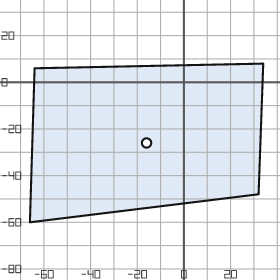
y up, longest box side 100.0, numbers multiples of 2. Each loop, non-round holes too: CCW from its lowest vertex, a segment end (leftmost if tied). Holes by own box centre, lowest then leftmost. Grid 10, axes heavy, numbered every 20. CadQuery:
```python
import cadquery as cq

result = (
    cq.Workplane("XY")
    .moveTo(-66.0, -60.0)
    .lineTo(32.0, -48.0)
    .lineTo(34.0, 8.0)
    .lineTo(-64.0, 6.0)
    .close()
    .moveTo(-16.0, -26.0)
    .circle(2.0)
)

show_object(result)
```